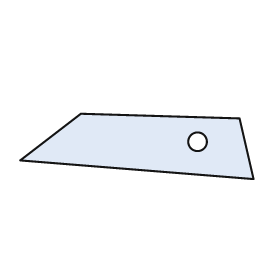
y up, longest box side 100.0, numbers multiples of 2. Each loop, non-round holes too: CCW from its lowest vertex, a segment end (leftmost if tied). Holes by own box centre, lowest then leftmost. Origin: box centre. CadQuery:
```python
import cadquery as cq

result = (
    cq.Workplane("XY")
    .moveTo(50.0, -14.0)
    .lineTo(44.0, 12.0)
    .lineTo(-24.0, 14.0)
    .lineTo(-50.0, -6.0)
    .close()
    .moveTo(26.0, 2.0)
    .circle(4.0)
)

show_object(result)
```